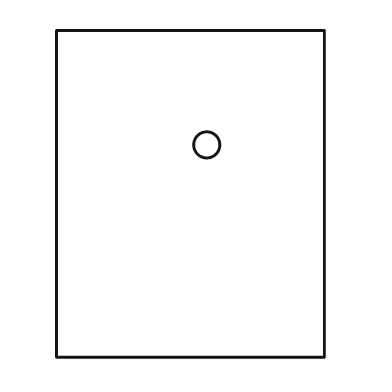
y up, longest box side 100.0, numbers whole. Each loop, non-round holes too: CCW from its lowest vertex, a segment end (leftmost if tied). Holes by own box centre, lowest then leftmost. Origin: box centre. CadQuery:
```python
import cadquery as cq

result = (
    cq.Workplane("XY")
    .moveTo(-41.0, -50.0)
    .lineTo(41.0, -50.0)
    .lineTo(41.0, 50.0)
    .lineTo(-41.0, 50.0)
    .close()
    .moveTo(5.0, 15.0)
    .circle(4.0)
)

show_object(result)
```